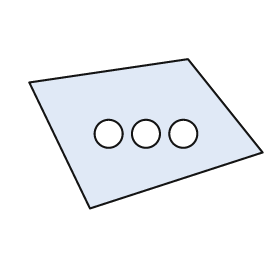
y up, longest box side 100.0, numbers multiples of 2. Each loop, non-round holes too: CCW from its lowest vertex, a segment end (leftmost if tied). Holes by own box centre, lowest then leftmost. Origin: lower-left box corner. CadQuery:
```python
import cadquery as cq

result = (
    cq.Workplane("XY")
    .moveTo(26.0, 0.0)
    .lineTo(100.0, 24.0)
    .lineTo(68.0, 64.0)
    .lineTo(0.0, 54.0)
    .close()
    .moveTo(34.0, 32.0)
    .circle(6.0)
    .moveTo(50.0, 32.0)
    .circle(6.0)
    .moveTo(66.0, 32.0)
    .circle(6.0)
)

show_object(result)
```